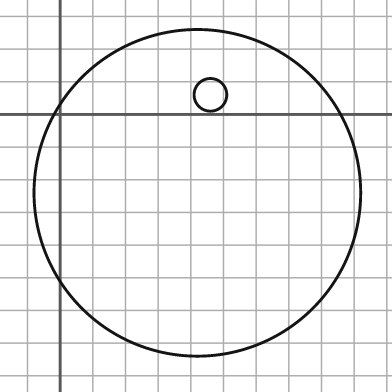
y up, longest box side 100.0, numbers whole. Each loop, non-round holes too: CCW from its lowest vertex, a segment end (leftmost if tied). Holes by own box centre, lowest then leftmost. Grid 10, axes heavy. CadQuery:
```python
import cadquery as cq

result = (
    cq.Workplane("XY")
    .moveTo(42.0, -24.0)
    .circle(50.0)
    .moveTo(46.0, 6.0)
    .circle(5.0)
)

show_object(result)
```